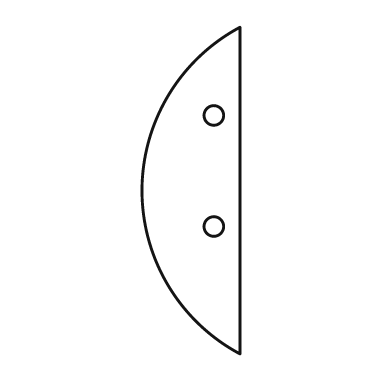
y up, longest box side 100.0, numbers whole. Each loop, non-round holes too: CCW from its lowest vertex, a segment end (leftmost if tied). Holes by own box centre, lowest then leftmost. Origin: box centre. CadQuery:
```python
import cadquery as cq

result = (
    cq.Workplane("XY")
    .moveTo(15.0, -50.0)
    .lineTo(15.0, 50.0)
    .threePointArc((-15.0, 0.0), (15.0, -50.0))
    .close()
    .moveTo(7.0, -11.0)
    .circle(3.0)
    .moveTo(7.0, 23.0)
    .circle(3.0)
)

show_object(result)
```